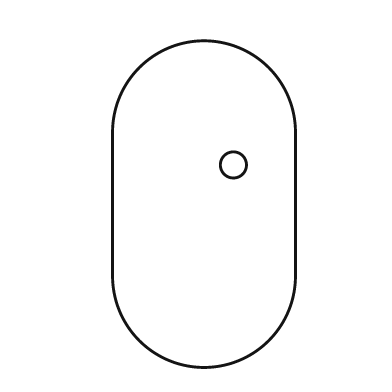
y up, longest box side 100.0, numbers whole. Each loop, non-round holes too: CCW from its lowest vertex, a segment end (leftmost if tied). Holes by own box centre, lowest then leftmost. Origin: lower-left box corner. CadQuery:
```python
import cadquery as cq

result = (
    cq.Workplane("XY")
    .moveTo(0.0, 28.0)
    .threePointArc((28.0, 0.0), (56.0, 28.0))
    .lineTo(56.0, 72.0)
    .threePointArc((28.0, 100.0), (0.0, 72.0))
    .close()
    .moveTo(37.0, 62.0)
    .circle(4.0)
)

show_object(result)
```